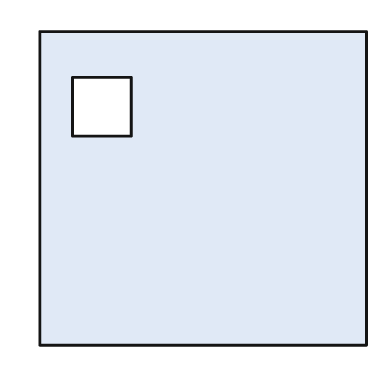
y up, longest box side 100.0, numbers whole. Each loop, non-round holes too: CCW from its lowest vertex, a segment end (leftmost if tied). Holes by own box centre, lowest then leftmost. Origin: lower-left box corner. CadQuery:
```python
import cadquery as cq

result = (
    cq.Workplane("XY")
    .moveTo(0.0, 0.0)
    .lineTo(100.0, 0.0)
    .lineTo(100.0, 96.0)
    .lineTo(0.0, 96.0)
    .close()
    .moveTo(10.0, 64.0)
    .lineTo(28.0, 64.0)
    .lineTo(28.0, 82.0)
    .lineTo(10.0, 82.0)
    .close()
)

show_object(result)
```